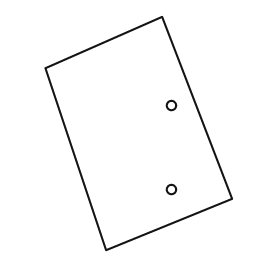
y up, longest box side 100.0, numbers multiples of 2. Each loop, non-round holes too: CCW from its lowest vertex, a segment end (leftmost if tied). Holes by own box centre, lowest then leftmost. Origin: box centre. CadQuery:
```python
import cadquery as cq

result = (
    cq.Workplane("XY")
    .moveTo(-14.0, -50.0)
    .lineTo(40.0, -28.0)
    .lineTo(10.0, 50.0)
    .lineTo(-40.0, 28.0)
    .close()
    .moveTo(14.0, -24.0)
    .circle(2.0)
    .moveTo(14.0, 12.0)
    .circle(2.0)
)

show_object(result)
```